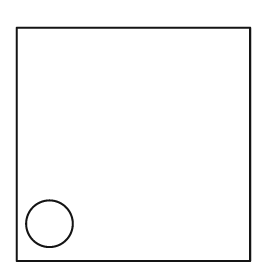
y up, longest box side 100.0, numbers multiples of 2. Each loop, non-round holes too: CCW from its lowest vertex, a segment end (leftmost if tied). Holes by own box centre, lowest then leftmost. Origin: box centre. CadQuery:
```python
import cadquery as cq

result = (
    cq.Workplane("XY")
    .moveTo(-50.0, -50.0)
    .lineTo(50.0, -50.0)
    .lineTo(50.0, 50.0)
    .lineTo(-50.0, 50.0)
    .close()
    .moveTo(-36.0, -34.0)
    .circle(10.0)
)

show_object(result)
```